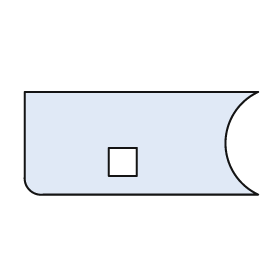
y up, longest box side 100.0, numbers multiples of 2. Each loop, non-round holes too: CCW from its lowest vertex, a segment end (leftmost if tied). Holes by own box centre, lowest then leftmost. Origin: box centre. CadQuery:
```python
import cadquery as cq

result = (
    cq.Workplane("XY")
    .moveTo(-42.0, -22.0)
    .lineTo(50.0, -22.0)
    .threePointArc((36.0, 0.0), (50.0, 22.0))
    .lineTo(-50.0, 22.0)
    .lineTo(-50.0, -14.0)
    .threePointArc((-48.0, -20.0), (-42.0, -22.0))
    .close()
    .moveTo(-14.0, -14.0)
    .lineTo(-2.0, -14.0)
    .lineTo(-2.0, -2.0)
    .lineTo(-14.0, -2.0)
    .close()
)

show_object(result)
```